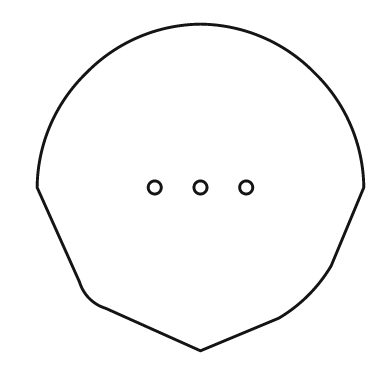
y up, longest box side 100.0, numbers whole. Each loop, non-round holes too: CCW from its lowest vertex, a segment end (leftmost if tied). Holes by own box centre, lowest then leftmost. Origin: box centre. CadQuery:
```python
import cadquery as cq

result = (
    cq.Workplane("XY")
    .moveTo(0.0, -50.0)
    .lineTo(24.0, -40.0)
    .threePointArc((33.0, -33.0), (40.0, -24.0))
    .lineTo(50.0, 0.0)
    .threePointArc((46.0, 19.0), (35.0, 35.0))
    .threePointArc((19.0, 46.0), (0.0, 50.0))
    .threePointArc((-19.0, 46.0), (-35.0, 35.0))
    .threePointArc((-46.0, 19.0), (-50.0, 0.0))
    .lineTo(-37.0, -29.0)
    .threePointArc((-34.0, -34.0), (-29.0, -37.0))
    .close()
    .moveTo(-14.0, 0.0)
    .circle(2.0)
    .moveTo(0.0, 0.0)
    .circle(2.0)
    .moveTo(14.0, 0.0)
    .circle(2.0)
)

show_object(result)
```